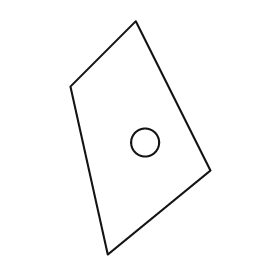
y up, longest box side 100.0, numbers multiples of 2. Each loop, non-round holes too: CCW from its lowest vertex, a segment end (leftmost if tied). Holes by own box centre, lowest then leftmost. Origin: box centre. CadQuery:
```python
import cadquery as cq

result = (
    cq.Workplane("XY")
    .moveTo(-14.0, -50.0)
    .lineTo(30.0, -14.0)
    .lineTo(-2.0, 50.0)
    .lineTo(-30.0, 22.0)
    .close()
    .moveTo(2.0, -2.0)
    .circle(6.0)
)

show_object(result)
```